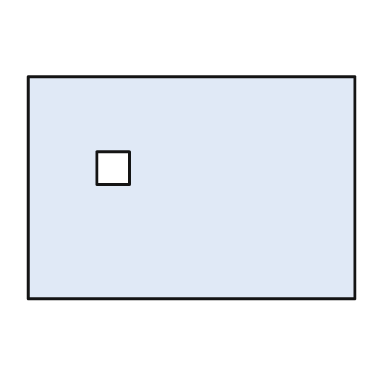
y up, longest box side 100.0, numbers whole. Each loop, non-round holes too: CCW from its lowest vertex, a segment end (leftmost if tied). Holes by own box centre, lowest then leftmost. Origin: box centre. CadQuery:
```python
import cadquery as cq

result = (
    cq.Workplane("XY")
    .moveTo(-50.0, -34.0)
    .lineTo(50.0, -34.0)
    .lineTo(50.0, 34.0)
    .lineTo(-50.0, 34.0)
    .close()
    .moveTo(-29.0, 1.0)
    .lineTo(-19.0, 1.0)
    .lineTo(-19.0, 11.0)
    .lineTo(-29.0, 11.0)
    .close()
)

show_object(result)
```